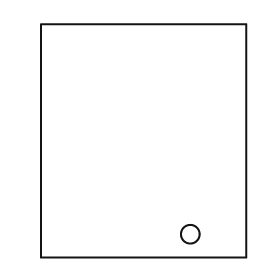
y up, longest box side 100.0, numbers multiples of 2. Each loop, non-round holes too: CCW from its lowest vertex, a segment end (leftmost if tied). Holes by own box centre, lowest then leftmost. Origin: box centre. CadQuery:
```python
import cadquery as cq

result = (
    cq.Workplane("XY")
    .moveTo(-44.0, -50.0)
    .lineTo(44.0, -50.0)
    .lineTo(44.0, 50.0)
    .lineTo(-44.0, 50.0)
    .close()
    .moveTo(20.0, -40.0)
    .circle(4.0)
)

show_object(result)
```